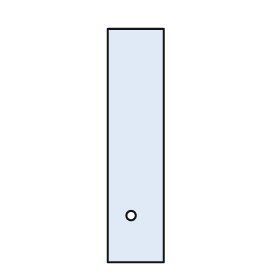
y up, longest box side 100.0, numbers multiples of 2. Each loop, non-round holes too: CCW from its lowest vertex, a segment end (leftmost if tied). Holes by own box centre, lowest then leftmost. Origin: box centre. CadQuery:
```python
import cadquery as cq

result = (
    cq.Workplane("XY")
    .moveTo(-12.0, -50.0)
    .lineTo(12.0, -50.0)
    .lineTo(12.0, 50.0)
    .lineTo(-12.0, 50.0)
    .close()
    .moveTo(-2.0, -30.0)
    .circle(2.0)
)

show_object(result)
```